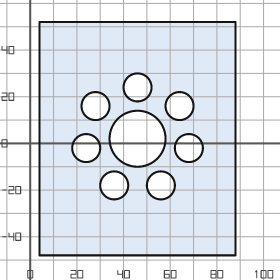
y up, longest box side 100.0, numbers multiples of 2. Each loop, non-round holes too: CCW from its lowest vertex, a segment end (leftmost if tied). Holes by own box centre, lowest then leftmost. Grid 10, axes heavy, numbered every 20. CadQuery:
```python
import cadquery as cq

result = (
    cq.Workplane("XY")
    .moveTo(4.0, -48.0)
    .lineTo(88.0, -48.0)
    .lineTo(88.0, 52.0)
    .lineTo(4.0, 52.0)
    .close()
    .moveTo(36.0, -18.0)
    .circle(6.0)
    .moveTo(56.0, -18.0)
    .circle(6.0)
    .moveTo(24.0, -2.0)
    .circle(6.0)
    .moveTo(68.0, -2.0)
    .circle(6.0)
    .moveTo(46.0, 2.0)
    .circle(12.0)
    .moveTo(28.0, 16.0)
    .circle(6.0)
    .moveTo(64.0, 16.0)
    .circle(6.0)
    .moveTo(46.0, 24.0)
    .circle(6.0)
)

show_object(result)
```